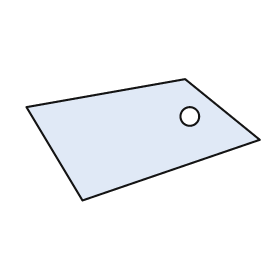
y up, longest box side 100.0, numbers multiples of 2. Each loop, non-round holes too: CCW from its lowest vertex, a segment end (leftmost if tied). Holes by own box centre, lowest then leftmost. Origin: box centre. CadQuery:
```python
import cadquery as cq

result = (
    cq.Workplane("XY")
    .moveTo(-26.0, -26.0)
    .lineTo(50.0, 0.0)
    .lineTo(18.0, 26.0)
    .lineTo(-50.0, 14.0)
    .close()
    .moveTo(20.0, 10.0)
    .circle(4.0)
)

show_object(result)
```